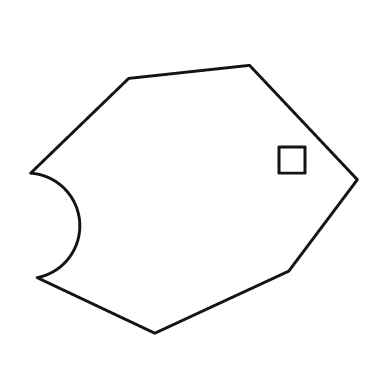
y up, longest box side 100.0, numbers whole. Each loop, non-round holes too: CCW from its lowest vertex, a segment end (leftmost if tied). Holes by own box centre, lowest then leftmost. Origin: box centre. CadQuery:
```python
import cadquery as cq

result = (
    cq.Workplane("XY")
    .moveTo(-12.0, -41.0)
    .lineTo(29.0, -22.0)
    .lineTo(50.0, 6.0)
    .lineTo(17.0, 41.0)
    .lineTo(-20.0, 37.0)
    .lineTo(-50.0, 8.0)
    .threePointArc((-35.0, -7.0), (-48.0, -24.0))
    .close()
    .moveTo(26.0, 8.0)
    .lineTo(34.0, 8.0)
    .lineTo(34.0, 16.0)
    .lineTo(26.0, 16.0)
    .close()
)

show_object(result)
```